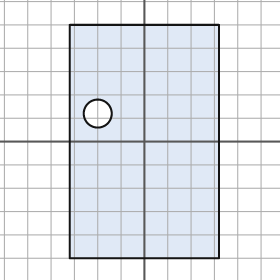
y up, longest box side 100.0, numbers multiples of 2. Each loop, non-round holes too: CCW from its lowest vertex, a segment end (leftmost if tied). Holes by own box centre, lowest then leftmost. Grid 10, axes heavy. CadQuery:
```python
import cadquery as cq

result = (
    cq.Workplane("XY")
    .moveTo(-32.0, -50.0)
    .lineTo(32.0, -50.0)
    .lineTo(32.0, 50.0)
    .lineTo(-32.0, 50.0)
    .close()
    .moveTo(-20.0, 12.0)
    .circle(6.0)
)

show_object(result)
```